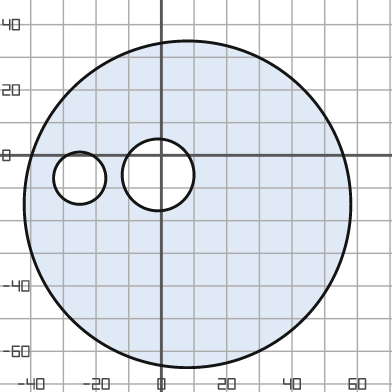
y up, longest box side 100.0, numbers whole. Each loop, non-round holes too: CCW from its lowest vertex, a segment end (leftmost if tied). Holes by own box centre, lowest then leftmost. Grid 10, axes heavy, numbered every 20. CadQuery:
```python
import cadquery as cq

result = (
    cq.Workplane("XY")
    .moveTo(8.0, -15.0)
    .circle(50.0)
    .moveTo(-25.0, -7.0)
    .circle(8.0)
    .moveTo(-1.0, -6.0)
    .circle(11.0)
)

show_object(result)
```